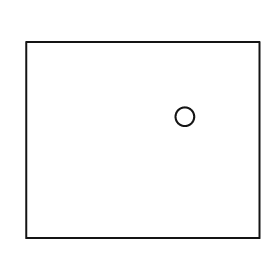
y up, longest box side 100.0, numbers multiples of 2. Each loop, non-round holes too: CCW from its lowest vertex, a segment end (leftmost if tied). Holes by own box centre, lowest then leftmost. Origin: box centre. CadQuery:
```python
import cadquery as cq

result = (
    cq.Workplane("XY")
    .moveTo(-50.0, -42.0)
    .lineTo(50.0, -42.0)
    .lineTo(50.0, 42.0)
    .lineTo(-50.0, 42.0)
    .close()
    .moveTo(18.0, 10.0)
    .circle(4.0)
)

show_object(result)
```